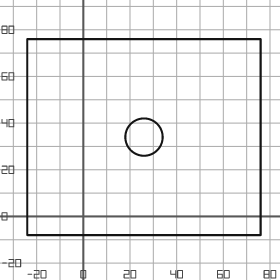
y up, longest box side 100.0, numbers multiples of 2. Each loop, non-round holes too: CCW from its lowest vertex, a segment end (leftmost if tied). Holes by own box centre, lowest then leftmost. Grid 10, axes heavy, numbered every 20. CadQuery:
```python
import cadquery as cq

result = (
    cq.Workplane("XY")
    .moveTo(-24.0, -8.0)
    .lineTo(76.0, -8.0)
    .lineTo(76.0, 76.0)
    .lineTo(-24.0, 76.0)
    .close()
    .moveTo(26.0, 34.0)
    .circle(8.0)
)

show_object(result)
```